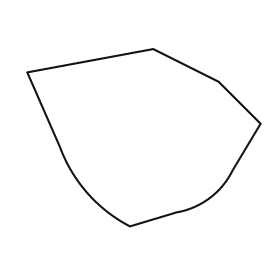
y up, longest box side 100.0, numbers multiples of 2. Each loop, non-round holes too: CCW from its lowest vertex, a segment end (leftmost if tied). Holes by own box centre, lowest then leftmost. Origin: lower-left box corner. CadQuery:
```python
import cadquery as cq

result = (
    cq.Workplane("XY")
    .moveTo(44.0, 0.0)
    .lineTo(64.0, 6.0)
    .threePointArc((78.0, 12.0), (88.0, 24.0))
    .lineTo(100.0, 44.0)
    .lineTo(82.0, 62.0)
    .lineTo(54.0, 76.0)
    .lineTo(0.0, 66.0)
    .lineTo(14.0, 34.0)
    .threePointArc((26.0, 14.0), (44.0, 0.0))
    .close()
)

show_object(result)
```